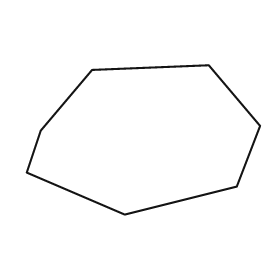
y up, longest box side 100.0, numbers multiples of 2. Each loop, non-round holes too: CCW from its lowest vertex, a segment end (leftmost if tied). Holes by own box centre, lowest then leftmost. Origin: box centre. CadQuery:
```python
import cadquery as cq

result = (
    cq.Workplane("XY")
    .moveTo(-8.0, -32.0)
    .lineTo(40.0, -20.0)
    .lineTo(50.0, 6.0)
    .lineTo(28.0, 32.0)
    .lineTo(-22.0, 30.0)
    .lineTo(-44.0, 4.0)
    .lineTo(-50.0, -14.0)
    .close()
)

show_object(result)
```